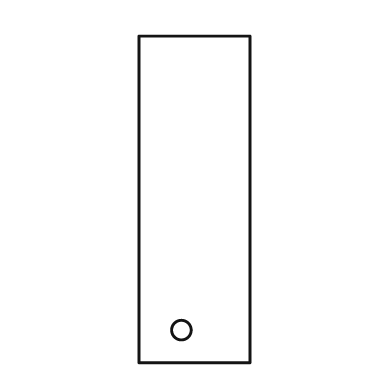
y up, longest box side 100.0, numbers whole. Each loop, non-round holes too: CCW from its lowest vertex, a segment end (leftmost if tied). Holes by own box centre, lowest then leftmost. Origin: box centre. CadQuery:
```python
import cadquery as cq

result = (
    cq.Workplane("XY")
    .moveTo(-17.0, -50.0)
    .lineTo(17.0, -50.0)
    .lineTo(17.0, 50.0)
    .lineTo(-17.0, 50.0)
    .close()
    .moveTo(-4.0, -40.0)
    .circle(3.0)
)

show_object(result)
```